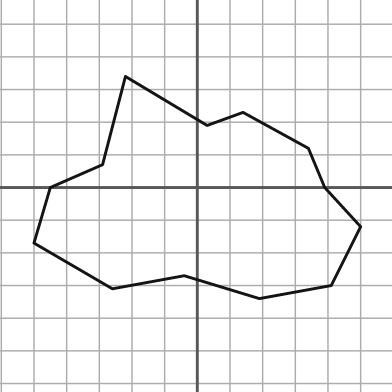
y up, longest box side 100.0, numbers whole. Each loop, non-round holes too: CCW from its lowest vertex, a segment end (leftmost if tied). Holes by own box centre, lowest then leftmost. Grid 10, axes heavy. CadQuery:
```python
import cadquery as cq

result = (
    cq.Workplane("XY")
    .moveTo(19.0, -34.0)
    .lineTo(41.0, -30.0)
    .lineTo(50.0, -12.0)
    .lineTo(39.0, 0.0)
    .lineTo(34.0, 12.0)
    .lineTo(14.0, 23.0)
    .lineTo(3.0, 19.0)
    .lineTo(-22.0, 34.0)
    .lineTo(-29.0, 7.0)
    .lineTo(-45.0, 0.0)
    .lineTo(-50.0, -17.0)
    .lineTo(-26.0, -31.0)
    .lineTo(-4.0, -27.0)
    .close()
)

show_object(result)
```